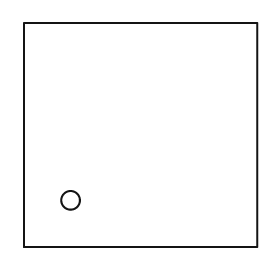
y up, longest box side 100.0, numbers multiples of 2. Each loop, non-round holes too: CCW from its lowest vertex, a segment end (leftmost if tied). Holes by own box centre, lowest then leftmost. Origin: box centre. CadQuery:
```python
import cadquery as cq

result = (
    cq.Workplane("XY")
    .moveTo(-50.0, -48.0)
    .lineTo(50.0, -48.0)
    .lineTo(50.0, 48.0)
    .lineTo(-50.0, 48.0)
    .close()
    .moveTo(-30.0, -28.0)
    .circle(4.0)
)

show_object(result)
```